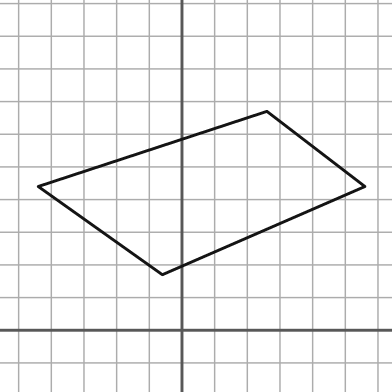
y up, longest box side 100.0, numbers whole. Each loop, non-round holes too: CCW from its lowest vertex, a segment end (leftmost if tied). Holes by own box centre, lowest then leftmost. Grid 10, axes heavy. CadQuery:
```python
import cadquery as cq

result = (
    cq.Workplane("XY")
    .moveTo(-6.0, 17.0)
    .lineTo(56.0, 44.0)
    .lineTo(26.0, 67.0)
    .lineTo(-44.0, 44.0)
    .close()
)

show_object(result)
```